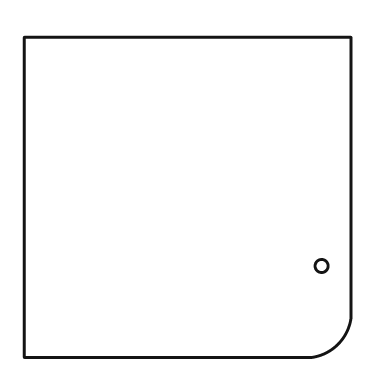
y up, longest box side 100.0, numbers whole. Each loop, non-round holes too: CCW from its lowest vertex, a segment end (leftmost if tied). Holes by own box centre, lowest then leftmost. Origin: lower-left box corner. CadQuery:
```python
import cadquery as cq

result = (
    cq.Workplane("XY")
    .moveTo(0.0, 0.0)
    .lineTo(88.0, 0.0)
    .threePointArc((96.0, 4.0), (100.0, 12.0))
    .lineTo(100.0, 98.0)
    .lineTo(0.0, 98.0)
    .close()
    .moveTo(91.0, 28.0)
    .circle(2.0)
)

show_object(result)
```